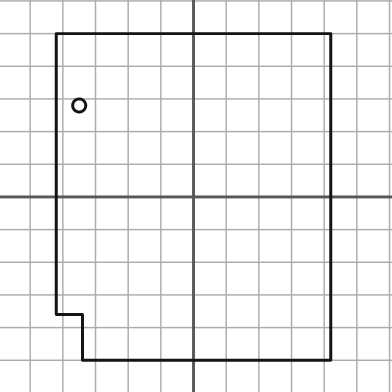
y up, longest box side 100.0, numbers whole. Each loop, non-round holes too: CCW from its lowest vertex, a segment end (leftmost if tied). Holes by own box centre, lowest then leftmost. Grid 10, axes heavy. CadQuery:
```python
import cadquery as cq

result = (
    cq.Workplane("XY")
    .moveTo(-34.0, -50.0)
    .lineTo(42.0, -50.0)
    .lineTo(42.0, 50.0)
    .lineTo(-42.0, 50.0)
    .lineTo(-42.0, -36.0)
    .lineTo(-34.0, -36.0)
    .close()
    .moveTo(-35.0, 28.0)
    .circle(2.0)
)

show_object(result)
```